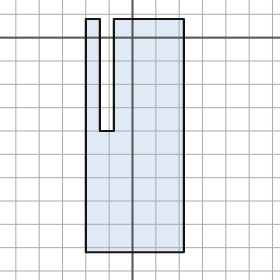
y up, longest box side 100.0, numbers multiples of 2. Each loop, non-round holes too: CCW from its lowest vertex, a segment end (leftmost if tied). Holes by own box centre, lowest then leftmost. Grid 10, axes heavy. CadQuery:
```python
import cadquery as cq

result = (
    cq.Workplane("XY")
    .moveTo(-20.0, -92.0)
    .lineTo(22.0, -92.0)
    .lineTo(22.0, 8.0)
    .lineTo(-8.0, 8.0)
    .lineTo(-8.0, -40.0)
    .lineTo(-14.0, -40.0)
    .lineTo(-14.0, 8.0)
    .lineTo(-20.0, 8.0)
    .close()
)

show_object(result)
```